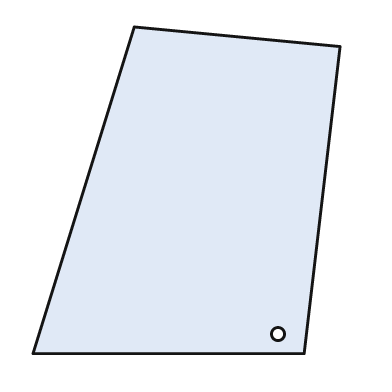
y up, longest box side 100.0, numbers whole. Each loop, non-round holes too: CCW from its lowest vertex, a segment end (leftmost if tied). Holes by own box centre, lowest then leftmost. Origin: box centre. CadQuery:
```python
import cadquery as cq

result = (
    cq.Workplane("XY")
    .moveTo(-47.0, -50.0)
    .lineTo(36.0, -50.0)
    .lineTo(47.0, 44.0)
    .lineTo(-16.0, 50.0)
    .close()
    .moveTo(28.0, -44.0)
    .circle(2.0)
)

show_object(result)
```